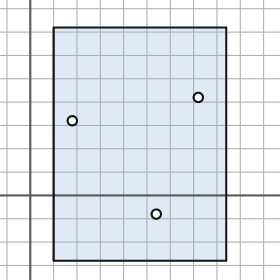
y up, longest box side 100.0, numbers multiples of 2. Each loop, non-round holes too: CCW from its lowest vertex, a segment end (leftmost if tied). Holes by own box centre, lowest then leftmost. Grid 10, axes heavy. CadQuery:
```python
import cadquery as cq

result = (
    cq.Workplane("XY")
    .moveTo(10.0, -28.0)
    .lineTo(84.0, -28.0)
    .lineTo(84.0, 72.0)
    .lineTo(10.0, 72.0)
    .close()
    .moveTo(54.0, -8.0)
    .circle(2.0)
    .moveTo(18.0, 32.0)
    .circle(2.0)
    .moveTo(72.0, 42.0)
    .circle(2.0)
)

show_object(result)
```